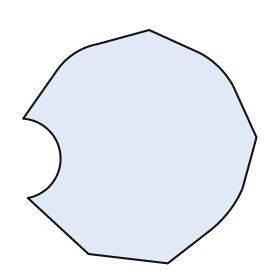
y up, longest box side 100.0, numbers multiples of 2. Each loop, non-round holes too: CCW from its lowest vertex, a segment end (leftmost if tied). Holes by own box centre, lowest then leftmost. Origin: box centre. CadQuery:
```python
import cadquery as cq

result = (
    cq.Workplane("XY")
    .moveTo(12.0, -50.0)
    .lineTo(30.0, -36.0)
    .threePointArc((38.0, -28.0), (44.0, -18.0))
    .lineTo(50.0, 4.0)
    .lineTo(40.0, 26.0)
    .threePointArc((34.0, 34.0), (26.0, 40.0))
    .lineTo(4.0, 50.0)
    .lineTo(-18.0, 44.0)
    .threePointArc((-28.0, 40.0), (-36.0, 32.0))
    .lineTo(-50.0, 12.0)
    .threePointArc((-34.0, -4.0), (-48.0, -22.0))
    .lineTo(-22.0, -46.0)
    .close()
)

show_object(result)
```